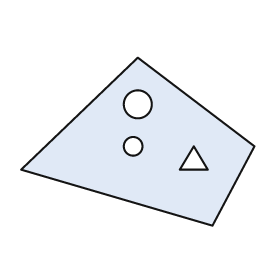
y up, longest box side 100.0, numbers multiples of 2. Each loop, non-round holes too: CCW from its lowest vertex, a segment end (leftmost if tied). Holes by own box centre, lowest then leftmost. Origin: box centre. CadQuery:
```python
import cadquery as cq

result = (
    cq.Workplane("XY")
    .moveTo(32.0, -36.0)
    .lineTo(50.0, -2.0)
    .lineTo(0.0, 36.0)
    .lineTo(-50.0, -12.0)
    .close()
    .moveTo(18.0, -12.0)
    .lineTo(30.0, -12.0)
    .lineTo(24.0, -2.0)
    .close()
    .moveTo(-2.0, -2.0)
    .circle(4.0)
    .moveTo(0.0, 16.0)
    .circle(6.0)
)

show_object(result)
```